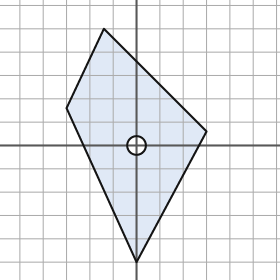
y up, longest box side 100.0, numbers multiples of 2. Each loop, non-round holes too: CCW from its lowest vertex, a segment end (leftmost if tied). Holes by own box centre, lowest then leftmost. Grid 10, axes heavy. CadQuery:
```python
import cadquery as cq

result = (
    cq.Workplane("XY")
    .moveTo(0.0, -50.0)
    .lineTo(30.0, 6.0)
    .lineTo(-14.0, 50.0)
    .lineTo(-30.0, 16.0)
    .close()
    .moveTo(0.0, 0.0)
    .circle(4.0)
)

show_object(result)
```